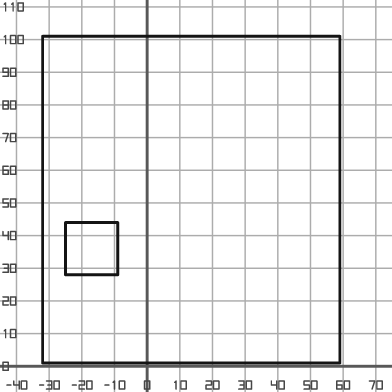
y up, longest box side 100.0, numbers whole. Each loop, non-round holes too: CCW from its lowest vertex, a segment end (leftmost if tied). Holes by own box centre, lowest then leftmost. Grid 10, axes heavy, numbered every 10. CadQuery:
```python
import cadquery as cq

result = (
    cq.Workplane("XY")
    .moveTo(-32.0, 1.0)
    .lineTo(59.0, 1.0)
    .lineTo(59.0, 101.0)
    .lineTo(-32.0, 101.0)
    .close()
    .moveTo(-25.0, 28.0)
    .lineTo(-9.0, 28.0)
    .lineTo(-9.0, 44.0)
    .lineTo(-25.0, 44.0)
    .close()
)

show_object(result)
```